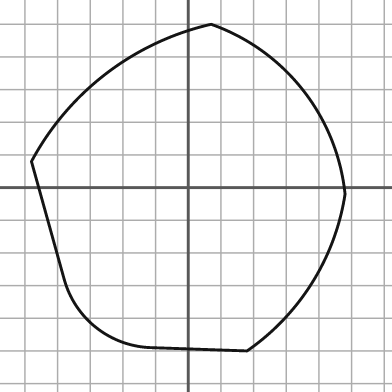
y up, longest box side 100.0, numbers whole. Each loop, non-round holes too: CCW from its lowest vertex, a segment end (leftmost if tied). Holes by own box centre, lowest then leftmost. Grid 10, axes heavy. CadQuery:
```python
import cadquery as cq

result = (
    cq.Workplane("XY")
    .moveTo(18.0, -50.0)
    .threePointArc((38.0, -29.0), (48.0, -2.0))
    .threePointArc((35.0, 30.0), (7.0, 50.0))
    .threePointArc((-25.0, 35.0), (-48.0, 8.0))
    .lineTo(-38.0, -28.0)
    .threePointArc((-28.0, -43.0), (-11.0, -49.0))
    .close()
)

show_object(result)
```